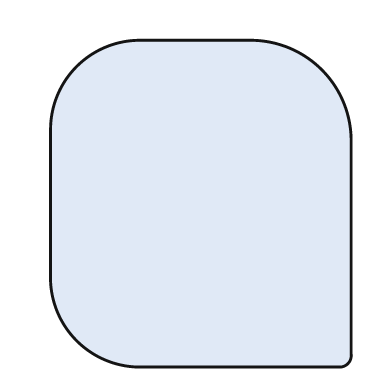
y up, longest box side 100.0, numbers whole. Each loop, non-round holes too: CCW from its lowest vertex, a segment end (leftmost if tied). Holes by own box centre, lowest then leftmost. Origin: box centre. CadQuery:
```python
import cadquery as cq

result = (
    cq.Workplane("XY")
    .moveTo(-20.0, -50.0)
    .lineTo(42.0, -50.0)
    .threePointArc((45.0, -49.0), (46.0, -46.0))
    .lineTo(46.0, 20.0)
    .threePointArc((37.0, 41.0), (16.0, 50.0))
    .lineTo(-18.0, 50.0)
    .threePointArc((-38.0, 42.0), (-46.0, 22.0))
    .lineTo(-46.0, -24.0)
    .threePointArc((-38.0, -42.0), (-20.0, -50.0))
    .close()
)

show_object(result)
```